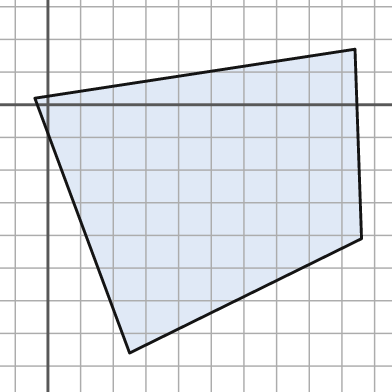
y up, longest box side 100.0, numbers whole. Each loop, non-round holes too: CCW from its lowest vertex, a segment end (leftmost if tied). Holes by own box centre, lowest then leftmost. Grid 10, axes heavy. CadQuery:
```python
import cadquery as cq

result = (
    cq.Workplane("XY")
    .moveTo(25.0, -76.0)
    .lineTo(96.0, -41.0)
    .lineTo(94.0, 17.0)
    .lineTo(-4.0, 2.0)
    .close()
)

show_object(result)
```